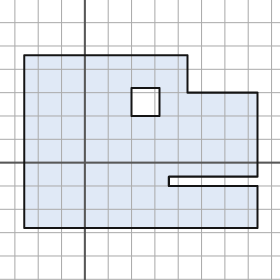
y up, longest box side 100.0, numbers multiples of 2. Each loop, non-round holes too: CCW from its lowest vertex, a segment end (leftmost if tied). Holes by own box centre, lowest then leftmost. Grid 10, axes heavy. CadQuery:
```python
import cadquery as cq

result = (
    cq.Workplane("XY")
    .moveTo(-26.0, -28.0)
    .lineTo(74.0, -28.0)
    .lineTo(74.0, -10.0)
    .lineTo(36.0, -10.0)
    .lineTo(36.0, -6.0)
    .lineTo(74.0, -6.0)
    .lineTo(74.0, 30.0)
    .lineTo(44.0, 30.0)
    .lineTo(44.0, 46.0)
    .lineTo(-26.0, 46.0)
    .close()
    .moveTo(20.0, 20.0)
    .lineTo(32.0, 20.0)
    .lineTo(32.0, 32.0)
    .lineTo(20.0, 32.0)
    .close()
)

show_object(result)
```